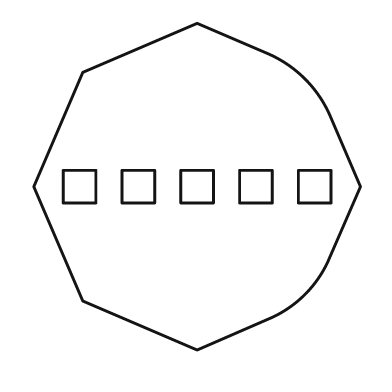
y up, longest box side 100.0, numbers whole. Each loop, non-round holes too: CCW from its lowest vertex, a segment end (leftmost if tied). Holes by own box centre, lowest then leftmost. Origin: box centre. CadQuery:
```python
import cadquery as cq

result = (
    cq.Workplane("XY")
    .moveTo(0.0, -50.0)
    .lineTo(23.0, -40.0)
    .threePointArc((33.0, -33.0), (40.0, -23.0))
    .lineTo(50.0, 0.0)
    .lineTo(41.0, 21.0)
    .threePointArc((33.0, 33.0), (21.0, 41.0))
    .lineTo(0.0, 50.0)
    .lineTo(-35.0, 35.0)
    .lineTo(-50.0, 0.0)
    .lineTo(-35.0, -35.0)
    .close()
    .moveTo(-41.0, -5.0)
    .lineTo(-31.0, -5.0)
    .lineTo(-31.0, 5.0)
    .lineTo(-41.0, 5.0)
    .close()
    .moveTo(-23.0, -5.0)
    .lineTo(-13.0, -5.0)
    .lineTo(-13.0, 5.0)
    .lineTo(-23.0, 5.0)
    .close()
    .moveTo(-5.0, -5.0)
    .lineTo(5.0, -5.0)
    .lineTo(5.0, 5.0)
    .lineTo(-5.0, 5.0)
    .close()
    .moveTo(13.0, -5.0)
    .lineTo(23.0, -5.0)
    .lineTo(23.0, 5.0)
    .lineTo(13.0, 5.0)
    .close()
    .moveTo(31.0, -5.0)
    .lineTo(41.0, -5.0)
    .lineTo(41.0, 5.0)
    .lineTo(31.0, 5.0)
    .close()
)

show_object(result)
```